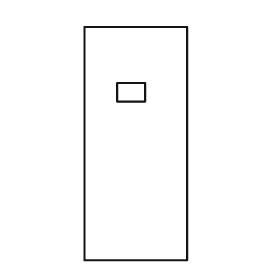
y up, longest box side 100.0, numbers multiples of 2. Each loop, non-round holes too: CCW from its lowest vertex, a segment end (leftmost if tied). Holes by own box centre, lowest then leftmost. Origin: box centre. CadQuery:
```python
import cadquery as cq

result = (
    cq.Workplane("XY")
    .moveTo(-22.0, -50.0)
    .lineTo(22.0, -50.0)
    .lineTo(22.0, 50.0)
    .lineTo(-22.0, 50.0)
    .close()
    .moveTo(-8.0, 18.0)
    .lineTo(4.0, 18.0)
    .lineTo(4.0, 26.0)
    .lineTo(-8.0, 26.0)
    .close()
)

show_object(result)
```